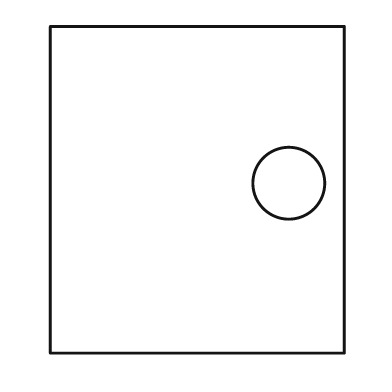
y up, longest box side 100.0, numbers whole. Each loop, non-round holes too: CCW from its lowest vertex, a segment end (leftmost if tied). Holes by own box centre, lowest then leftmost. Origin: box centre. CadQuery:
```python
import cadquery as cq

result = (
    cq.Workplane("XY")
    .moveTo(-45.0, -50.0)
    .lineTo(45.0, -50.0)
    .lineTo(45.0, 50.0)
    .lineTo(-45.0, 50.0)
    .close()
    .moveTo(28.0, 2.0)
    .circle(11.0)
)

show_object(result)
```